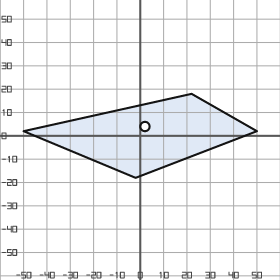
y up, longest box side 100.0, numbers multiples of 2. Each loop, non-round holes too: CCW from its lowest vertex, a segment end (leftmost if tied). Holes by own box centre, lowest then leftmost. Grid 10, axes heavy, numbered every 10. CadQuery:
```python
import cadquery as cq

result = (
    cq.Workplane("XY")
    .moveTo(-2.0, -18.0)
    .lineTo(50.0, 2.0)
    .lineTo(22.0, 18.0)
    .lineTo(-50.0, 2.0)
    .close()
    .moveTo(2.0, 4.0)
    .circle(2.0)
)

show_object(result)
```